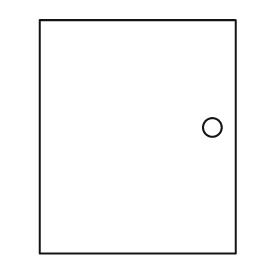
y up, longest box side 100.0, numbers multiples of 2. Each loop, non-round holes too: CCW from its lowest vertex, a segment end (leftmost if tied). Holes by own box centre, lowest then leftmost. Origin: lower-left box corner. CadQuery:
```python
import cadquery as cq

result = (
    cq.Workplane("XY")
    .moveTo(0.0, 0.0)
    .lineTo(84.0, 0.0)
    .lineTo(84.0, 100.0)
    .lineTo(0.0, 100.0)
    .close()
    .moveTo(74.0, 54.0)
    .circle(4.0)
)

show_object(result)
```